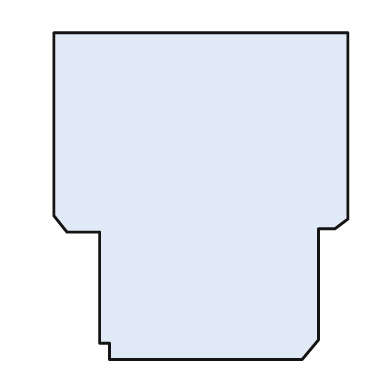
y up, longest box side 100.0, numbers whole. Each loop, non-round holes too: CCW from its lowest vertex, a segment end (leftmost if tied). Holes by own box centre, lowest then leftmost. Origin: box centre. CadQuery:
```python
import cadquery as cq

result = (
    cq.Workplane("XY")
    .moveTo(-28.0, -50.0)
    .lineTo(31.0, -50.0)
    .lineTo(36.0, -44.0)
    .lineTo(36.0, -10.0)
    .lineTo(41.0, -10.0)
    .lineTo(45.0, -7.0)
    .lineTo(45.0, 50.0)
    .lineTo(-45.0, 50.0)
    .lineTo(-45.0, -6.0)
    .lineTo(-41.0, -11.0)
    .lineTo(-31.0, -11.0)
    .lineTo(-31.0, -45.0)
    .lineTo(-28.0, -45.0)
    .close()
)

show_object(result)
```